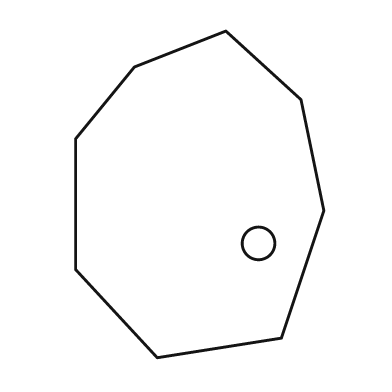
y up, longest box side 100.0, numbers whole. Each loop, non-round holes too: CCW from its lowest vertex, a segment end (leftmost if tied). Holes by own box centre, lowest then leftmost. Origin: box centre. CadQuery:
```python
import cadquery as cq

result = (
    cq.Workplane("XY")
    .moveTo(-13.0, -50.0)
    .lineTo(25.0, -44.0)
    .lineTo(38.0, -5.0)
    .lineTo(31.0, 29.0)
    .lineTo(8.0, 50.0)
    .lineTo(-20.0, 39.0)
    .lineTo(-38.0, 17.0)
    .lineTo(-38.0, -23.0)
    .close()
    .moveTo(18.0, -15.0)
    .circle(5.0)
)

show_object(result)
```